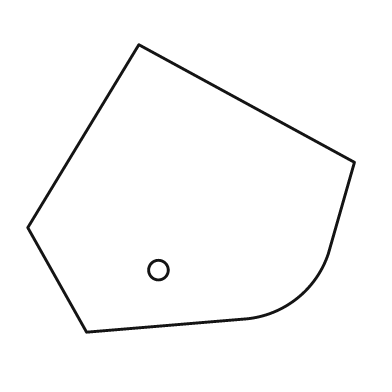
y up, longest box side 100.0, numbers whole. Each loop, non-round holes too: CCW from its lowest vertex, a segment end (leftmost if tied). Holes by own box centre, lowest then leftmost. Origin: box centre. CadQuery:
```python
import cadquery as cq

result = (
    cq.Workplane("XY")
    .moveTo(-32.0, -44.0)
    .lineTo(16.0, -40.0)
    .threePointArc((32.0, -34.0), (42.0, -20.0))
    .lineTo(50.0, 8.0)
    .lineTo(-16.0, 44.0)
    .lineTo(-50.0, -12.0)
    .close()
    .moveTo(-10.0, -25.0)
    .circle(3.0)
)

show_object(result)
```